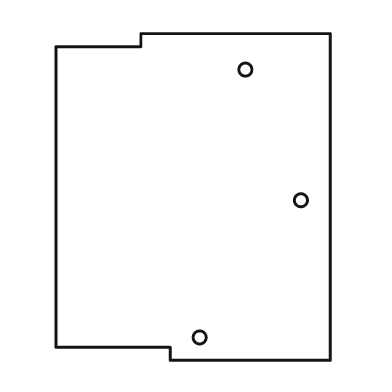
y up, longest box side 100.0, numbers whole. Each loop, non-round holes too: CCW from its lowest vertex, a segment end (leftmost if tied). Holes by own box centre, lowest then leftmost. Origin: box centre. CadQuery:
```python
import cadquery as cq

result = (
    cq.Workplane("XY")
    .moveTo(-7.0, -50.0)
    .lineTo(42.0, -50.0)
    .lineTo(42.0, 50.0)
    .lineTo(-16.0, 50.0)
    .lineTo(-16.0, 46.0)
    .lineTo(-42.0, 46.0)
    .lineTo(-42.0, -46.0)
    .lineTo(-7.0, -46.0)
    .close()
    .moveTo(2.0, -43.0)
    .circle(2.0)
    .moveTo(33.0, -1.0)
    .circle(2.0)
    .moveTo(16.0, 39.0)
    .circle(2.0)
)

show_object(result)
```